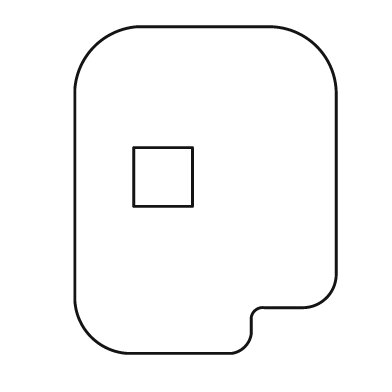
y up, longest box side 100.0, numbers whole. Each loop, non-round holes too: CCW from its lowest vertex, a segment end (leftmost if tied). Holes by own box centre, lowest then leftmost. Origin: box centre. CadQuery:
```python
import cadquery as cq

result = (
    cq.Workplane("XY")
    .moveTo(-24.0, -50.0)
    .lineTo(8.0, -50.0)
    .threePointArc((12.0, -48.0), (14.0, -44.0))
    .lineTo(14.0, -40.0)
    .threePointArc((15.0, -37.0), (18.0, -36.0))
    .lineTo(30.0, -36.0)
    .threePointArc((37.0, -33.0), (40.0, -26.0))
    .lineTo(40.0, 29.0)
    .threePointArc((34.0, 44.0), (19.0, 50.0))
    .lineTo(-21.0, 50.0)
    .threePointArc((-34.0, 44.0), (-40.0, 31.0))
    .lineTo(-40.0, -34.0)
    .threePointArc((-35.0, -45.0), (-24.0, -50.0))
    .close()
    .moveTo(-22.0, -5.0)
    .lineTo(-4.0, -5.0)
    .lineTo(-4.0, 13.0)
    .lineTo(-22.0, 13.0)
    .close()
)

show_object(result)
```